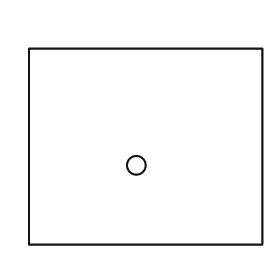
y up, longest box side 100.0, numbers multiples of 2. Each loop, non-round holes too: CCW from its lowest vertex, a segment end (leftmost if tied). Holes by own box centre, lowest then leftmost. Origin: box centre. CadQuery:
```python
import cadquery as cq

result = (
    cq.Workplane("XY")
    .moveTo(-50.0, -42.0)
    .lineTo(50.0, -42.0)
    .lineTo(50.0, 42.0)
    .lineTo(-50.0, 42.0)
    .close()
    .moveTo(-4.0, -8.0)
    .circle(4.0)
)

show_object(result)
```